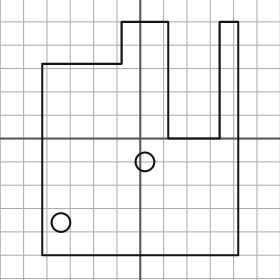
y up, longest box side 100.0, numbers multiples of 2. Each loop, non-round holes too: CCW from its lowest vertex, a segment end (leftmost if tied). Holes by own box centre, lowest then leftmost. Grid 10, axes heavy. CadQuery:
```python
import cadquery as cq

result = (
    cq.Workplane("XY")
    .moveTo(-42.0, -50.0)
    .lineTo(42.0, -50.0)
    .lineTo(42.0, 50.0)
    .lineTo(34.0, 50.0)
    .lineTo(34.0, 0.0)
    .lineTo(12.0, 0.0)
    .lineTo(12.0, 50.0)
    .lineTo(-8.0, 50.0)
    .lineTo(-8.0, 32.0)
    .lineTo(-42.0, 32.0)
    .close()
    .moveTo(-34.0, -36.0)
    .circle(4.0)
    .moveTo(2.0, -10.0)
    .circle(4.0)
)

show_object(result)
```